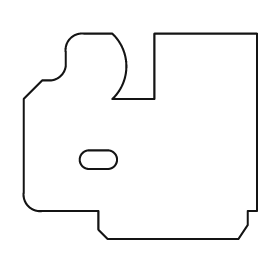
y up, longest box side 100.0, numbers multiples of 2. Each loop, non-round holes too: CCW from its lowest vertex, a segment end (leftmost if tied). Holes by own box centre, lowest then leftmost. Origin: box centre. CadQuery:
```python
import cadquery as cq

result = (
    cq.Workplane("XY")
    .moveTo(-14.0, -44.0)
    .lineTo(42.0, -44.0)
    .lineTo(46.0, -38.0)
    .lineTo(46.0, -32.0)
    .lineTo(50.0, -32.0)
    .lineTo(50.0, 44.0)
    .lineTo(6.0, 44.0)
    .lineTo(6.0, 16.0)
    .lineTo(-12.0, 16.0)
    .threePointArc((-6.0, 30.0), (-12.0, 44.0))
    .lineTo(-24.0, 44.0)
    .threePointArc((-30.0, 42.0), (-32.0, 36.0))
    .lineTo(-32.0, 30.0)
    .threePointArc((-34.0, 26.0), (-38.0, 24.0))
    .lineTo(-42.0, 24.0)
    .lineTo(-50.0, 16.0)
    .lineTo(-50.0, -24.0)
    .threePointArc((-48.0, -30.0), (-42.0, -32.0))
    .lineTo(-18.0, -32.0)
    .lineTo(-18.0, -40.0)
    .close()
    .moveTo(-22.0, -14.0)
    .lineTo(-14.0, -14.0)
    .threePointArc((-10.0, -10.0), (-14.0, -6.0))
    .lineTo(-22.0, -6.0)
    .threePointArc((-26.0, -10.0), (-22.0, -14.0))
    .close()
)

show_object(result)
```